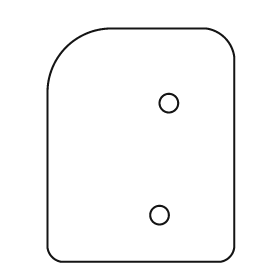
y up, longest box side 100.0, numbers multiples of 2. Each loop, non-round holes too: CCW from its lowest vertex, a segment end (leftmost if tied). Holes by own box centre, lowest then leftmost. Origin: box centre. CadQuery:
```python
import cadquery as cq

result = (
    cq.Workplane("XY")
    .moveTo(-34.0, -50.0)
    .lineTo(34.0, -50.0)
    .threePointArc((38.0, -48.0), (40.0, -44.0))
    .lineTo(40.0, 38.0)
    .threePointArc((36.0, 46.0), (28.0, 50.0))
    .lineTo(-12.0, 50.0)
    .threePointArc((-32.0, 42.0), (-40.0, 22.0))
    .lineTo(-40.0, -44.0)
    .threePointArc((-38.0, -48.0), (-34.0, -50.0))
    .close()
    .moveTo(8.0, -30.0)
    .circle(4.0)
    .moveTo(12.0, 18.0)
    .circle(4.0)
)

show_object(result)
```